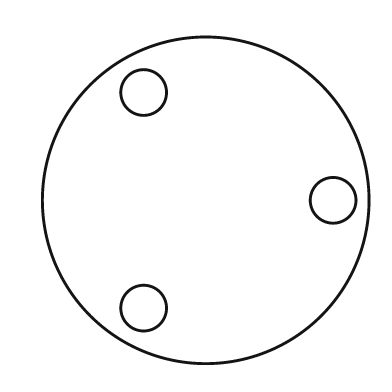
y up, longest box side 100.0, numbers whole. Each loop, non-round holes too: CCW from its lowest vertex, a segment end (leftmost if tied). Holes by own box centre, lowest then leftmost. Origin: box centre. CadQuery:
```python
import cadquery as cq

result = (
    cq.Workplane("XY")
    .moveTo(0.0, 0.0)
    .circle(50.0)
    .moveTo(-19.0, -33.0)
    .circle(7.0)
    .moveTo(39.0, 0.0)
    .circle(7.0)
    .moveTo(-19.0, 33.0)
    .circle(7.0)
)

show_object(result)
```